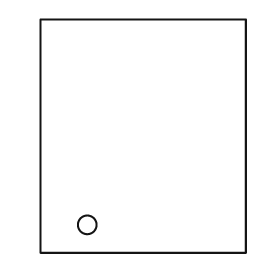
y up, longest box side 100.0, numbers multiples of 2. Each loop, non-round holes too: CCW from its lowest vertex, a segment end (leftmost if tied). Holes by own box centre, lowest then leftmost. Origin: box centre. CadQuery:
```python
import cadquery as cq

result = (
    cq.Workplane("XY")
    .moveTo(-44.0, -50.0)
    .lineTo(44.0, -50.0)
    .lineTo(44.0, 50.0)
    .lineTo(-44.0, 50.0)
    .close()
    .moveTo(-24.0, -38.0)
    .circle(4.0)
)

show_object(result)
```